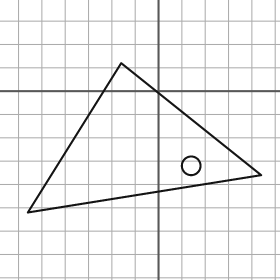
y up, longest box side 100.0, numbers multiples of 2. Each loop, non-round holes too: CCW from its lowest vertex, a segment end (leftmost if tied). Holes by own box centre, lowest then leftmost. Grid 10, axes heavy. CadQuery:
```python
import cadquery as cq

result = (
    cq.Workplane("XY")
    .moveTo(-56.0, -52.0)
    .lineTo(44.0, -36.0)
    .lineTo(-16.0, 12.0)
    .close()
    .moveTo(14.0, -32.0)
    .circle(4.0)
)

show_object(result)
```